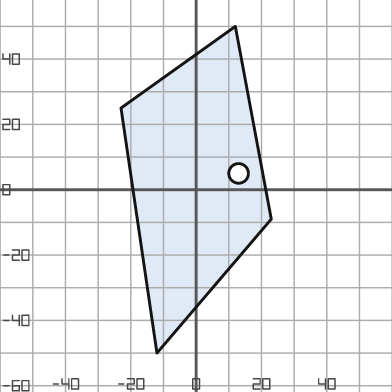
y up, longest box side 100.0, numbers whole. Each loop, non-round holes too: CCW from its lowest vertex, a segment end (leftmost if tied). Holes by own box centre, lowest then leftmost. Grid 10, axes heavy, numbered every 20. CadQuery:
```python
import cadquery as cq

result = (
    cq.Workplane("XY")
    .moveTo(-12.0, -50.0)
    .lineTo(23.0, -9.0)
    .lineTo(12.0, 50.0)
    .lineTo(-23.0, 25.0)
    .close()
    .moveTo(13.0, 5.0)
    .circle(3.0)
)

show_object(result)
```